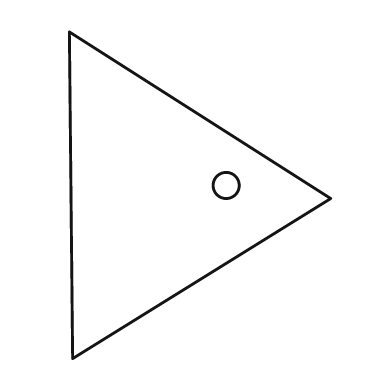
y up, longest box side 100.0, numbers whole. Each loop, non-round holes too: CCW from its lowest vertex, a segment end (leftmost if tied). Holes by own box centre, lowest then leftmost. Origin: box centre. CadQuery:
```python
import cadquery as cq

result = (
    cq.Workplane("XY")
    .moveTo(-39.0, -50.0)
    .lineTo(40.0, -1.0)
    .lineTo(-40.0, 50.0)
    .close()
    .moveTo(8.0, 3.0)
    .circle(4.0)
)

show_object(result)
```